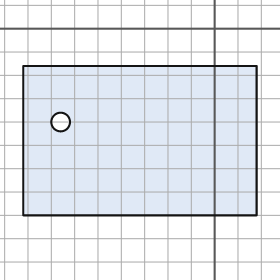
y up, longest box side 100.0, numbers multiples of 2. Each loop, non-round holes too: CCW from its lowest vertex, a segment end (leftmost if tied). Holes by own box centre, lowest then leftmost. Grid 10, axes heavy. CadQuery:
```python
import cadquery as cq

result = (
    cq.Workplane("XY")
    .moveTo(-82.0, -80.0)
    .lineTo(18.0, -80.0)
    .lineTo(18.0, -16.0)
    .lineTo(-82.0, -16.0)
    .close()
    .moveTo(-66.0, -40.0)
    .circle(4.0)
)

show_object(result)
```